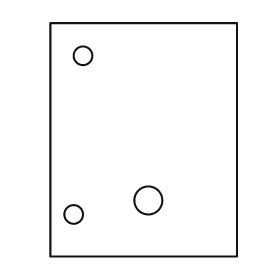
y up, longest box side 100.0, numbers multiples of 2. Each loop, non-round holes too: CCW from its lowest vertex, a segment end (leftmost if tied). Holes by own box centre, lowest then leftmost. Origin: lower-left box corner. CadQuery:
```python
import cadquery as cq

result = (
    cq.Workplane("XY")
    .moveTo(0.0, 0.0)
    .lineTo(80.0, 0.0)
    .lineTo(80.0, 100.0)
    .lineTo(0.0, 100.0)
    .close()
    .moveTo(10.0, 18.0)
    .circle(4.0)
    .moveTo(42.0, 24.0)
    .circle(6.0)
    .moveTo(14.0, 86.0)
    .circle(4.0)
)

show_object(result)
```